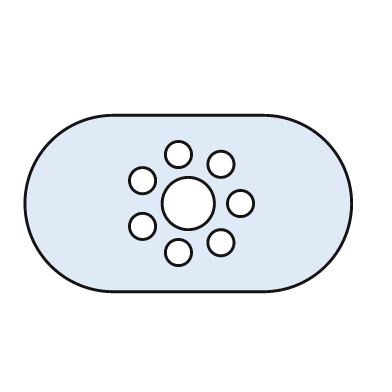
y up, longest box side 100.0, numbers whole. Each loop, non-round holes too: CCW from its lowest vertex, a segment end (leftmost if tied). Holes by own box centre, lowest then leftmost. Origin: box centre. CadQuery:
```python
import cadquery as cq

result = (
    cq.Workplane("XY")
    .moveTo(-23.0, -27.0)
    .lineTo(23.0, -27.0)
    .threePointArc((50.0, 0.0), (23.0, 27.0))
    .lineTo(-23.0, 27.0)
    .threePointArc((-50.0, 0.0), (-23.0, -27.0))
    .close()
    .moveTo(-3.0, -15.0)
    .circle(4.0)
    .moveTo(10.0, -12.0)
    .circle(4.0)
    .moveTo(-14.0, -7.0)
    .circle(4.0)
    .moveTo(0.0, 0.0)
    .circle(8.0)
    .moveTo(16.0, 0.0)
    .circle(4.0)
    .moveTo(-14.0, 7.0)
    .circle(4.0)
    .moveTo(10.0, 12.0)
    .circle(4.0)
    .moveTo(-3.0, 15.0)
    .circle(4.0)
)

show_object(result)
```